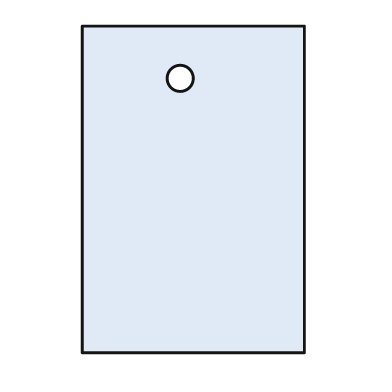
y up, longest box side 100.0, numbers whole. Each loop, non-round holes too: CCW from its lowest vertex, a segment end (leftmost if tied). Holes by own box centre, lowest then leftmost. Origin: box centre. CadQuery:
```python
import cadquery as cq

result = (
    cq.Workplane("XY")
    .moveTo(-34.0, -50.0)
    .lineTo(34.0, -50.0)
    .lineTo(34.0, 50.0)
    .lineTo(-34.0, 50.0)
    .close()
    .moveTo(-4.0, 34.0)
    .circle(4.0)
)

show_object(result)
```